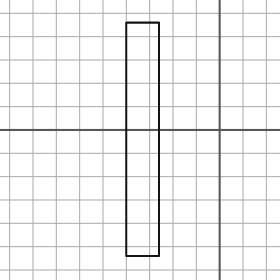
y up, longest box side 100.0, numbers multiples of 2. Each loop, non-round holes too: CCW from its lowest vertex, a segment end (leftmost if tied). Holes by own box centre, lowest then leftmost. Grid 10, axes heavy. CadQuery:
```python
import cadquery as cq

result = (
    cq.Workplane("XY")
    .moveTo(-40.0, -54.0)
    .lineTo(-26.0, -54.0)
    .lineTo(-26.0, 46.0)
    .lineTo(-40.0, 46.0)
    .close()
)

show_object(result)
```